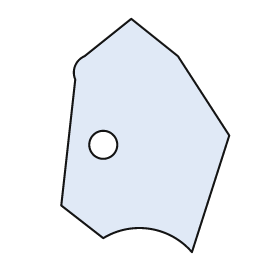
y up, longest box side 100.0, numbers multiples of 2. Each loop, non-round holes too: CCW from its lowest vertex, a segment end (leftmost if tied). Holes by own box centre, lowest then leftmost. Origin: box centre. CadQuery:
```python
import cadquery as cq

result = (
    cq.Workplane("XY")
    .moveTo(20.0, -50.0)
    .lineTo(36.0, 0.0)
    .lineTo(14.0, 34.0)
    .lineTo(-6.0, 50.0)
    .lineTo(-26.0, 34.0)
    .threePointArc((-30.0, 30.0), (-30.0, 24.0))
    .lineTo(-36.0, -30.0)
    .lineTo(-18.0, -44.0)
    .threePointArc((2.0, -40.0), (20.0, -50.0))
    .close()
    .moveTo(-18.0, -4.0)
    .circle(6.0)
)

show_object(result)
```